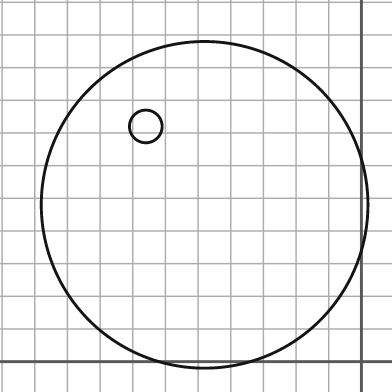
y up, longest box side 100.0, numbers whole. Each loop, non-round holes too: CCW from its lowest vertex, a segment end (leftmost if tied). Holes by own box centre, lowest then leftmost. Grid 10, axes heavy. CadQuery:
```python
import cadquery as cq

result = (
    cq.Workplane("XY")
    .moveTo(-48.0, 48.0)
    .circle(50.0)
    .moveTo(-66.0, 72.0)
    .circle(5.0)
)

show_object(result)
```